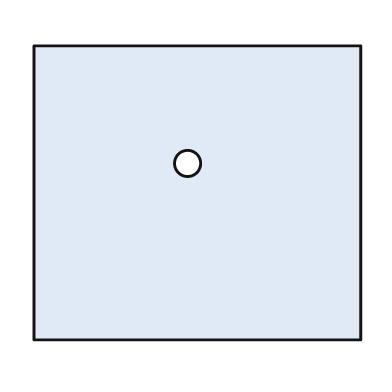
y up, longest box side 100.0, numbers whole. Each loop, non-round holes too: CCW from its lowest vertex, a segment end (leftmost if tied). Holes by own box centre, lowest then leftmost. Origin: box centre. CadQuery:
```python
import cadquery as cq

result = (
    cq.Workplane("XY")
    .moveTo(-50.0, -45.0)
    .lineTo(50.0, -45.0)
    .lineTo(50.0, 45.0)
    .lineTo(-50.0, 45.0)
    .close()
    .moveTo(-3.0, 9.0)
    .circle(4.0)
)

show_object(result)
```